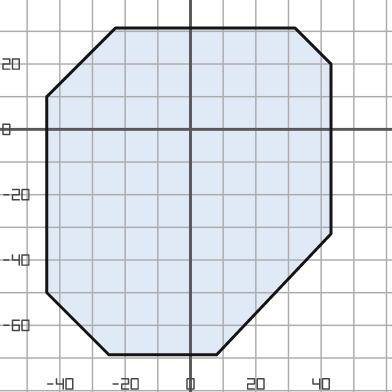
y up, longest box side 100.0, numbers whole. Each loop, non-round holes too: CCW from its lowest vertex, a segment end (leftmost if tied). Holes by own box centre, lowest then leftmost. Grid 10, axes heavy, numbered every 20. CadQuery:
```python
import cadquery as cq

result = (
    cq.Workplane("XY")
    .moveTo(-25.0, -69.0)
    .lineTo(8.0, -69.0)
    .lineTo(43.0, -32.0)
    .lineTo(43.0, 20.0)
    .lineTo(32.0, 31.0)
    .lineTo(-23.0, 31.0)
    .lineTo(-44.0, 10.0)
    .lineTo(-44.0, -50.0)
    .close()
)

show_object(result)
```